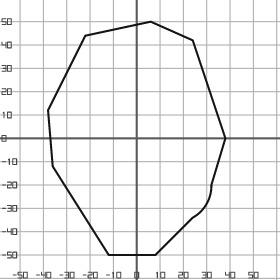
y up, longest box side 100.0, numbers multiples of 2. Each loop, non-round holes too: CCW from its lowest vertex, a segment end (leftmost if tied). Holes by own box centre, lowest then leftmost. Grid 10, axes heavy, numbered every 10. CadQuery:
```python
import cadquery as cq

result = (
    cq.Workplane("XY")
    .moveTo(-12.0, -50.0)
    .lineTo(8.0, -50.0)
    .lineTo(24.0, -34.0)
    .threePointArc((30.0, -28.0), (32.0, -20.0))
    .lineTo(38.0, 0.0)
    .lineTo(24.0, 42.0)
    .lineTo(6.0, 50.0)
    .lineTo(-22.0, 44.0)
    .lineTo(-38.0, 12.0)
    .lineTo(-36.0, -12.0)
    .close()
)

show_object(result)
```